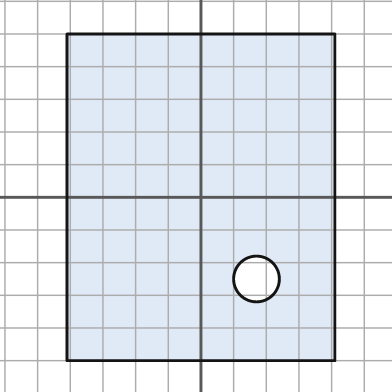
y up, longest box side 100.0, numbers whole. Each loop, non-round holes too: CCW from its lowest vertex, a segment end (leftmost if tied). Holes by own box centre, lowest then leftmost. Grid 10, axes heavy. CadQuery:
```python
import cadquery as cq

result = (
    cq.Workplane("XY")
    .moveTo(-41.0, -50.0)
    .lineTo(41.0, -50.0)
    .lineTo(41.0, 50.0)
    .lineTo(-41.0, 50.0)
    .close()
    .moveTo(17.0, -25.0)
    .circle(7.0)
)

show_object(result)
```